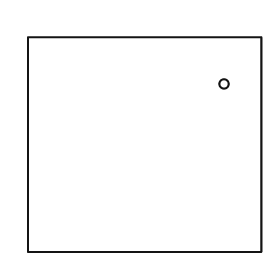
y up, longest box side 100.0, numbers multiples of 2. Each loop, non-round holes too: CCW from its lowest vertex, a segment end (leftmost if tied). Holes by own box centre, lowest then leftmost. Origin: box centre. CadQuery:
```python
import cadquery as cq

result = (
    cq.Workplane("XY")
    .moveTo(-50.0, -46.0)
    .lineTo(50.0, -46.0)
    .lineTo(50.0, 46.0)
    .lineTo(-50.0, 46.0)
    .close()
    .moveTo(34.0, 26.0)
    .circle(2.0)
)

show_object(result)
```